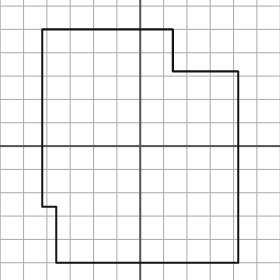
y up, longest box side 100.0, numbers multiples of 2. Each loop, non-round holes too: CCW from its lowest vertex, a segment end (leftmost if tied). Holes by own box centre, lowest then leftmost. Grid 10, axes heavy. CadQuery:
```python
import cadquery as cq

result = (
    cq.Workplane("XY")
    .moveTo(-36.0, -50.0)
    .lineTo(42.0, -50.0)
    .lineTo(42.0, 32.0)
    .lineTo(14.0, 32.0)
    .lineTo(14.0, 50.0)
    .lineTo(-42.0, 50.0)
    .lineTo(-42.0, -26.0)
    .lineTo(-36.0, -26.0)
    .close()
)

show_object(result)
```